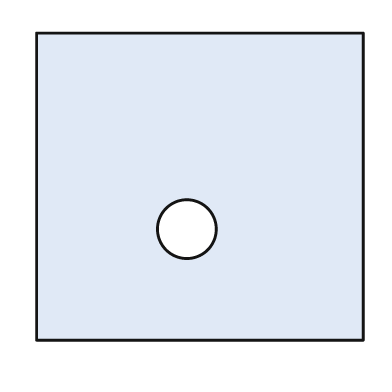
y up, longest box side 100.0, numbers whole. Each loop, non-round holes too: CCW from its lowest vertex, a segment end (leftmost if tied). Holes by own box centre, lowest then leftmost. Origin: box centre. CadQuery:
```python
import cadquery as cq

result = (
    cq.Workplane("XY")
    .moveTo(-50.0, -47.0)
    .lineTo(50.0, -47.0)
    .lineTo(50.0, 47.0)
    .lineTo(-50.0, 47.0)
    .close()
    .moveTo(-4.0, -13.0)
    .circle(9.0)
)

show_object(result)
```